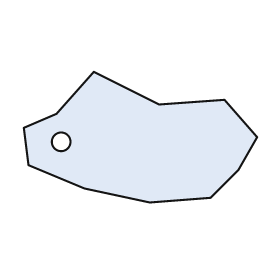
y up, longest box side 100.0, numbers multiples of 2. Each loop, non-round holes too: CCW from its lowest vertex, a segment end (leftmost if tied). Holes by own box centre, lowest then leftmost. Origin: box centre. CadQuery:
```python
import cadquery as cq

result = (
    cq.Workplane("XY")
    .moveTo(4.0, -28.0)
    .lineTo(30.0, -26.0)
    .lineTo(42.0, -14.0)
    .lineTo(50.0, 0.0)
    .lineTo(36.0, 16.0)
    .lineTo(8.0, 14.0)
    .lineTo(-20.0, 28.0)
    .lineTo(-36.0, 10.0)
    .lineTo(-50.0, 4.0)
    .lineTo(-48.0, -12.0)
    .lineTo(-24.0, -22.0)
    .close()
    .moveTo(-34.0, -2.0)
    .circle(4.0)
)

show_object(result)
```